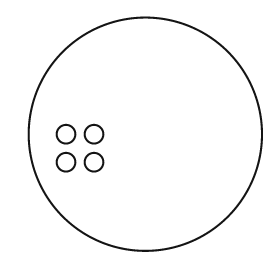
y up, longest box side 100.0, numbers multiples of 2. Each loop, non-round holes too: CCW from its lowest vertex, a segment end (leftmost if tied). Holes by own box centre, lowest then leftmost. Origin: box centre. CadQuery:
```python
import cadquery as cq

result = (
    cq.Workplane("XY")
    .moveTo(0.0, 0.0)
    .circle(50.0)
    .moveTo(-34.0, -12.0)
    .circle(4.0)
    .moveTo(-22.0, -12.0)
    .circle(4.0)
    .moveTo(-34.0, 0.0)
    .circle(4.0)
    .moveTo(-22.0, 0.0)
    .circle(4.0)
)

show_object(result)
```